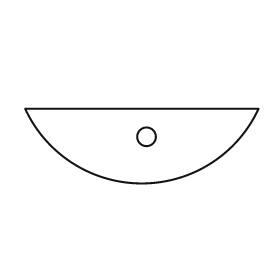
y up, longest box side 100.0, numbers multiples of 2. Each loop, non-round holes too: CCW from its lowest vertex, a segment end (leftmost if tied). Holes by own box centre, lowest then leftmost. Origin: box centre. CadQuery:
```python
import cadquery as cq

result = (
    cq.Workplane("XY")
    .moveTo(-50.0, 16.0)
    .threePointArc((0.0, -16.0), (50.0, 16.0))
    .close()
    .moveTo(2.0, 4.0)
    .circle(4.0)
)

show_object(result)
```